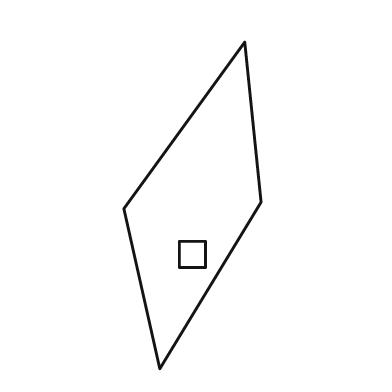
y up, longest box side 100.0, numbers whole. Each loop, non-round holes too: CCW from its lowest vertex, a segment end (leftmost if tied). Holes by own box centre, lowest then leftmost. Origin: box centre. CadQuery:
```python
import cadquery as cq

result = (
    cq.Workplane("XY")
    .moveTo(-10.0, -50.0)
    .lineTo(21.0, 1.0)
    .lineTo(16.0, 50.0)
    .lineTo(-21.0, -1.0)
    .close()
    .moveTo(-4.0, -19.0)
    .lineTo(4.0, -19.0)
    .lineTo(4.0, -11.0)
    .lineTo(-4.0, -11.0)
    .close()
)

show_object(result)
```